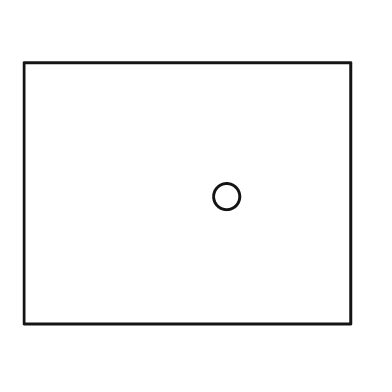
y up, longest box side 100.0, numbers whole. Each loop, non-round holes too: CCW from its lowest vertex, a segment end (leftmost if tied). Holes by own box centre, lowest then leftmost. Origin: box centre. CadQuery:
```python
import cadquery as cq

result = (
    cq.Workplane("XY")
    .moveTo(-50.0, -40.0)
    .lineTo(50.0, -40.0)
    .lineTo(50.0, 40.0)
    .lineTo(-50.0, 40.0)
    .close()
    .moveTo(12.0, -1.0)
    .circle(4.0)
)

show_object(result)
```